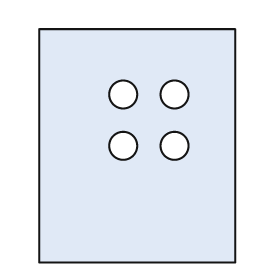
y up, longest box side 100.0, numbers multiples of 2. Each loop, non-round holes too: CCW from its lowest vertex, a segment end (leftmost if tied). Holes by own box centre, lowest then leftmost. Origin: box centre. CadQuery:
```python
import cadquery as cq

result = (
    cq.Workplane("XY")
    .moveTo(-42.0, -50.0)
    .lineTo(42.0, -50.0)
    .lineTo(42.0, 50.0)
    .lineTo(-42.0, 50.0)
    .close()
    .moveTo(-6.0, 0.0)
    .circle(6.0)
    .moveTo(16.0, 0.0)
    .circle(6.0)
    .moveTo(-6.0, 22.0)
    .circle(6.0)
    .moveTo(16.0, 22.0)
    .circle(6.0)
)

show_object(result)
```